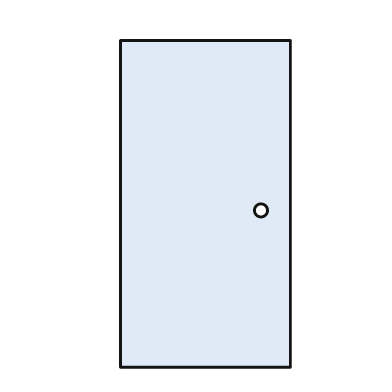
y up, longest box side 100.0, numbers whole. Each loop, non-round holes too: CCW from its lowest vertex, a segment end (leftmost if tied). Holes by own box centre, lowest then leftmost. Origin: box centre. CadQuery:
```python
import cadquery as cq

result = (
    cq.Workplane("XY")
    .moveTo(-26.0, -50.0)
    .lineTo(26.0, -50.0)
    .lineTo(26.0, 50.0)
    .lineTo(-26.0, 50.0)
    .close()
    .moveTo(17.0, -2.0)
    .circle(2.0)
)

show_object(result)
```